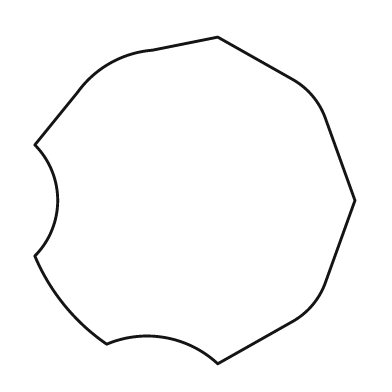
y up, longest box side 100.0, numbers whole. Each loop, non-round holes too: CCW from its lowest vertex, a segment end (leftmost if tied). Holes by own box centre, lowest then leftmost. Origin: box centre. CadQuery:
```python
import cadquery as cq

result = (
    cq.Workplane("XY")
    .moveTo(7.0, -50.0)
    .lineTo(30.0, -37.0)
    .threePointArc((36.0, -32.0), (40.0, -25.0))
    .lineTo(49.0, 0.0)
    .lineTo(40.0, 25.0)
    .threePointArc((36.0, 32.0), (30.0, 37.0))
    .lineTo(7.0, 50.0)
    .lineTo(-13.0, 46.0)
    .threePointArc((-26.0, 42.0), (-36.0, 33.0))
    .lineTo(-49.0, 17.0)
    .threePointArc((-42.0, 0.0), (-49.0, -17.0))
    .threePointArc((-40.0, -32.0), (-27.0, -44.0))
    .threePointArc((-9.0, -42.0), (7.0, -50.0))
    .close()
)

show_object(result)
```